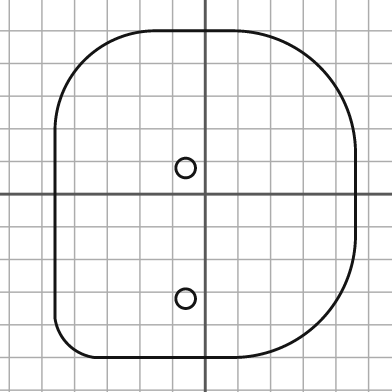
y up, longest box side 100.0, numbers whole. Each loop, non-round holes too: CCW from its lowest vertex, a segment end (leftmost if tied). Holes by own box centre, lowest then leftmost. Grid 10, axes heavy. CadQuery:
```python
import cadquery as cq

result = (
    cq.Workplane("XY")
    .moveTo(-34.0, -50.0)
    .lineTo(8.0, -50.0)
    .threePointArc((35.0, -39.0), (46.0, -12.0))
    .lineTo(46.0, 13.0)
    .threePointArc((35.0, 39.0), (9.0, 50.0))
    .lineTo(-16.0, 50.0)
    .threePointArc((-37.0, 41.0), (-46.0, 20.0))
    .lineTo(-46.0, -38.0)
    .threePointArc((-42.0, -46.0), (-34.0, -50.0))
    .close()
    .moveTo(-6.0, -32.0)
    .circle(3.0)
    .moveTo(-6.0, 8.0)
    .circle(3.0)
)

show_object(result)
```